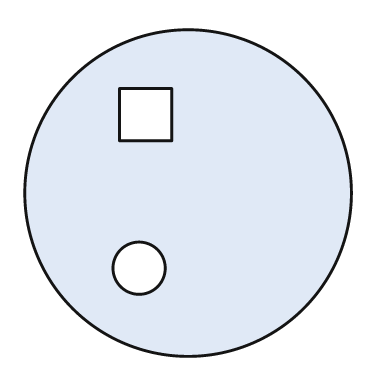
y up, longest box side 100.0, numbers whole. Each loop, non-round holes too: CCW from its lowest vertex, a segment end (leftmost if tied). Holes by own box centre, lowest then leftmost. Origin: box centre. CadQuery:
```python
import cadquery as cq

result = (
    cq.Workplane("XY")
    .moveTo(0.0, 0.0)
    .circle(50.0)
    .moveTo(-15.0, -23.0)
    .circle(8.0)
    .moveTo(-21.0, 16.0)
    .lineTo(-5.0, 16.0)
    .lineTo(-5.0, 32.0)
    .lineTo(-21.0, 32.0)
    .close()
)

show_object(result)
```